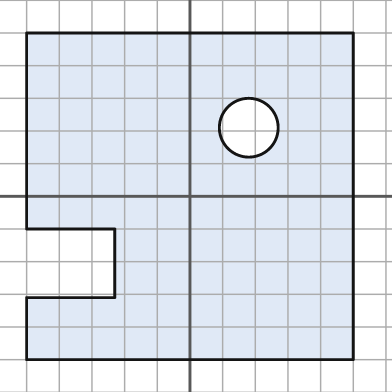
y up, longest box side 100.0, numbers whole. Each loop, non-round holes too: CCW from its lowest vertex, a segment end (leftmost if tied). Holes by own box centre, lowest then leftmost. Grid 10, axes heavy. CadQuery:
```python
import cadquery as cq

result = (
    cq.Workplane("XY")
    .moveTo(-50.0, -50.0)
    .lineTo(50.0, -50.0)
    .lineTo(50.0, 50.0)
    .lineTo(-50.0, 50.0)
    .lineTo(-50.0, -10.0)
    .lineTo(-23.0, -10.0)
    .lineTo(-23.0, -31.0)
    .lineTo(-50.0, -31.0)
    .close()
    .moveTo(18.0, 21.0)
    .circle(9.0)
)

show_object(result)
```